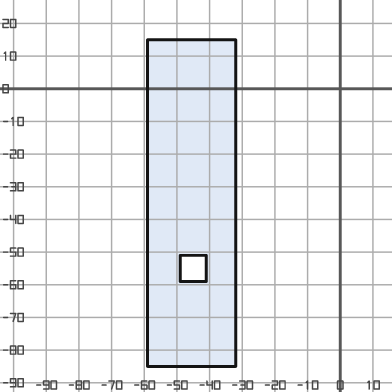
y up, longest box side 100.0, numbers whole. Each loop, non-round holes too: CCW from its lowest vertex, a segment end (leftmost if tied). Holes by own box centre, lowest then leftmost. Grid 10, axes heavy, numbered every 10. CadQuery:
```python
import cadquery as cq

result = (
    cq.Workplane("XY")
    .moveTo(-59.0, -85.0)
    .lineTo(-32.0, -85.0)
    .lineTo(-32.0, 15.0)
    .lineTo(-59.0, 15.0)
    .close()
    .moveTo(-49.0, -59.0)
    .lineTo(-41.0, -59.0)
    .lineTo(-41.0, -51.0)
    .lineTo(-49.0, -51.0)
    .close()
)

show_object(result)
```